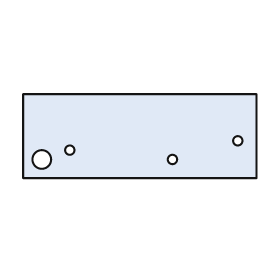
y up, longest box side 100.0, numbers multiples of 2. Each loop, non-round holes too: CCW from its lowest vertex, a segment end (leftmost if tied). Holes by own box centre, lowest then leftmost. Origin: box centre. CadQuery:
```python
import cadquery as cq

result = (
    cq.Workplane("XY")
    .moveTo(-50.0, -18.0)
    .lineTo(50.0, -18.0)
    .lineTo(50.0, 18.0)
    .lineTo(-50.0, 18.0)
    .close()
    .moveTo(-42.0, -10.0)
    .circle(4.0)
    .moveTo(14.0, -10.0)
    .circle(2.0)
    .moveTo(-30.0, -6.0)
    .circle(2.0)
    .moveTo(42.0, -2.0)
    .circle(2.0)
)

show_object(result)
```